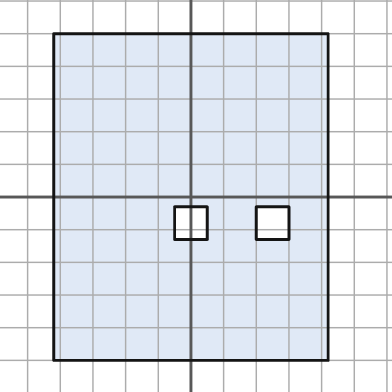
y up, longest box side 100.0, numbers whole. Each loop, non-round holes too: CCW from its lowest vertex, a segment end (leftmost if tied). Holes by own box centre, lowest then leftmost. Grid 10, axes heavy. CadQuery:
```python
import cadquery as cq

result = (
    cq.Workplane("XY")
    .moveTo(-42.0, -50.0)
    .lineTo(42.0, -50.0)
    .lineTo(42.0, 50.0)
    .lineTo(-42.0, 50.0)
    .close()
    .moveTo(-5.0, -13.0)
    .lineTo(5.0, -13.0)
    .lineTo(5.0, -3.0)
    .lineTo(-5.0, -3.0)
    .close()
    .moveTo(20.0, -13.0)
    .lineTo(30.0, -13.0)
    .lineTo(30.0, -3.0)
    .lineTo(20.0, -3.0)
    .close()
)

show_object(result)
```